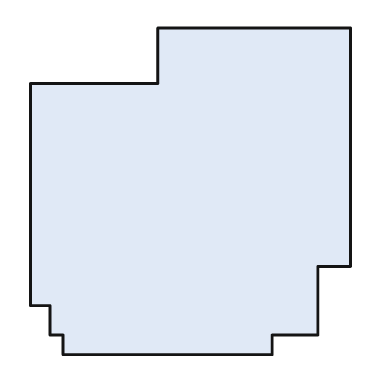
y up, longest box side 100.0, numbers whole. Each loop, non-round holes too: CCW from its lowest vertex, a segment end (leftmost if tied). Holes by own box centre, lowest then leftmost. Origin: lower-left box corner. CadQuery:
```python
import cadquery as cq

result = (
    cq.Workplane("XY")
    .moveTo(10.0, 0.0)
    .lineTo(74.0, 0.0)
    .lineTo(74.0, 6.0)
    .lineTo(88.0, 6.0)
    .lineTo(88.0, 27.0)
    .lineTo(98.0, 27.0)
    .lineTo(98.0, 100.0)
    .lineTo(39.0, 100.0)
    .lineTo(39.0, 83.0)
    .lineTo(0.0, 83.0)
    .lineTo(0.0, 15.0)
    .lineTo(6.0, 15.0)
    .lineTo(6.0, 6.0)
    .lineTo(10.0, 6.0)
    .close()
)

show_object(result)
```